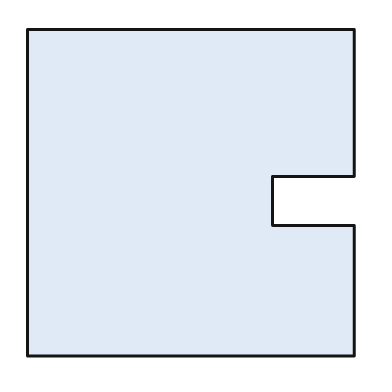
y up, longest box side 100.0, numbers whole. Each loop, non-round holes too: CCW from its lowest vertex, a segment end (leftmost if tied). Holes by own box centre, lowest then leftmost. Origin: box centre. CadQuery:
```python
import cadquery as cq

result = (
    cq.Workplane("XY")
    .moveTo(-50.0, -50.0)
    .lineTo(50.0, -50.0)
    .lineTo(50.0, -10.0)
    .lineTo(25.0, -10.0)
    .lineTo(25.0, 5.0)
    .lineTo(50.0, 5.0)
    .lineTo(50.0, 50.0)
    .lineTo(-50.0, 50.0)
    .close()
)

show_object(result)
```